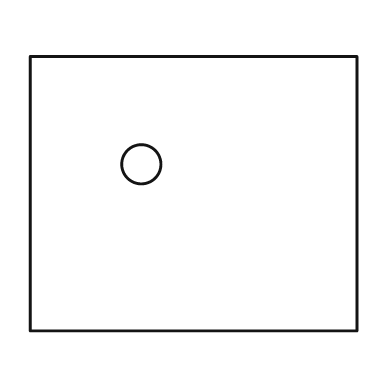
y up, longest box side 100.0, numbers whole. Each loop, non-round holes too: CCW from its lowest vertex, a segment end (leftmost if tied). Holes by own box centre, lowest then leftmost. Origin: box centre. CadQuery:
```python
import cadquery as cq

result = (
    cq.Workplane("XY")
    .moveTo(-50.0, -42.0)
    .lineTo(50.0, -42.0)
    .lineTo(50.0, 42.0)
    .lineTo(-50.0, 42.0)
    .close()
    .moveTo(-16.0, 9.0)
    .circle(6.0)
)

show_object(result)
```